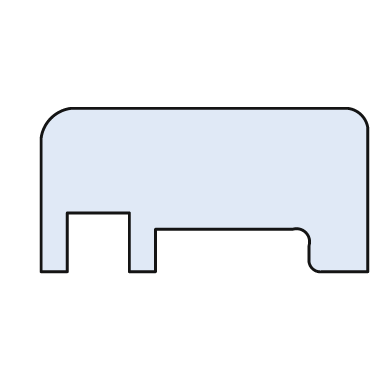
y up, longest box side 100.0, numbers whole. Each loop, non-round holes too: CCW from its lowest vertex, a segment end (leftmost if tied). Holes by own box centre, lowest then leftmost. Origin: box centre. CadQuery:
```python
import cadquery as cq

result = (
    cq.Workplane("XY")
    .moveTo(-50.0, -25.0)
    .lineTo(-42.0, -25.0)
    .lineTo(-42.0, -7.0)
    .lineTo(-23.0, -7.0)
    .lineTo(-23.0, -25.0)
    .lineTo(-15.0, -25.0)
    .lineTo(-15.0, -12.0)
    .lineTo(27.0, -12.0)
    .threePointArc((31.0, -13.0), (32.0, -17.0))
    .lineTo(32.0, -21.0)
    .threePointArc((33.0, -24.0), (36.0, -25.0))
    .lineTo(50.0, -25.0)
    .lineTo(50.0, 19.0)
    .threePointArc((48.0, 23.0), (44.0, 25.0))
    .lineTo(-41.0, 25.0)
    .threePointArc((-47.0, 22.0), (-50.0, 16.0))
    .close()
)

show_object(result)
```